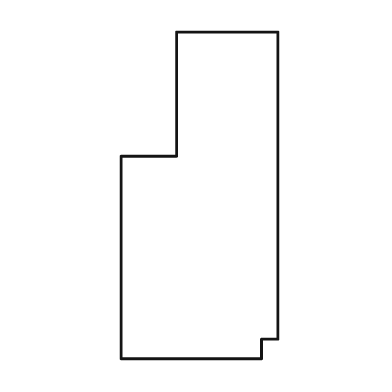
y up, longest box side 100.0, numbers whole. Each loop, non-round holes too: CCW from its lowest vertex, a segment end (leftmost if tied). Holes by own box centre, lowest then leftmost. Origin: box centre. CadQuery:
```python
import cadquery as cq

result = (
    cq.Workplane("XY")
    .moveTo(-24.0, -50.0)
    .lineTo(19.0, -50.0)
    .lineTo(19.0, -44.0)
    .lineTo(24.0, -44.0)
    .lineTo(24.0, 50.0)
    .lineTo(-7.0, 50.0)
    .lineTo(-7.0, 12.0)
    .lineTo(-24.0, 12.0)
    .close()
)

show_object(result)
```